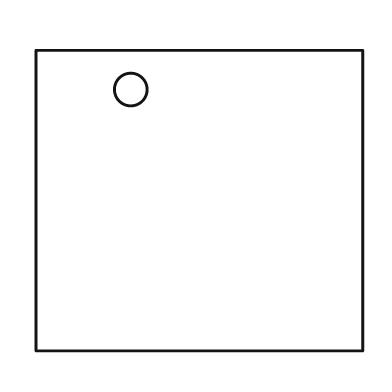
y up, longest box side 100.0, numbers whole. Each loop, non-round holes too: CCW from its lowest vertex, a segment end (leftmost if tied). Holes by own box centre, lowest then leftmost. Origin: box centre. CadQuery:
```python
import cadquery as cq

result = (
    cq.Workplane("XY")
    .moveTo(-50.0, -46.0)
    .lineTo(50.0, -46.0)
    .lineTo(50.0, 46.0)
    .lineTo(-50.0, 46.0)
    .close()
    .moveTo(-21.0, 34.0)
    .circle(5.0)
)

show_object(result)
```